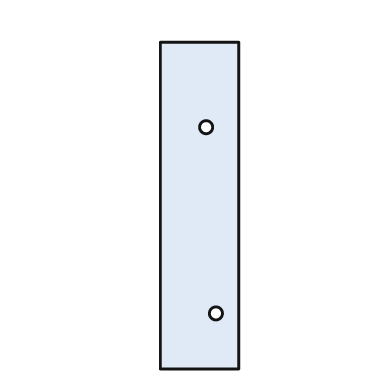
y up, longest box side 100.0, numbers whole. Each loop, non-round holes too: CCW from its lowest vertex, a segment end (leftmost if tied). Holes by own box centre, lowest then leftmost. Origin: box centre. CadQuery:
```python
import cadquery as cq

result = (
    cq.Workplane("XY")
    .moveTo(-12.0, -50.0)
    .lineTo(12.0, -50.0)
    .lineTo(12.0, 50.0)
    .lineTo(-12.0, 50.0)
    .close()
    .moveTo(5.0, -33.0)
    .circle(2.0)
    .moveTo(2.0, 24.0)
    .circle(2.0)
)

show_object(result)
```